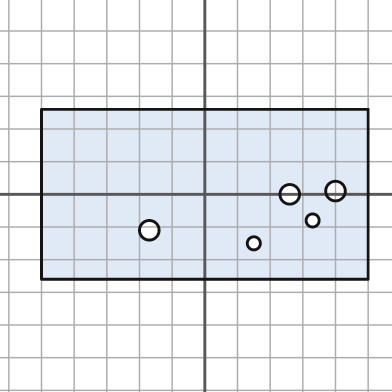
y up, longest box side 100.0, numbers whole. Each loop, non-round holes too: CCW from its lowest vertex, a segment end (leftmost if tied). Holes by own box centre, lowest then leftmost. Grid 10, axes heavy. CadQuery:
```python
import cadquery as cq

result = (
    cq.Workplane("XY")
    .moveTo(-50.0, -26.0)
    .lineTo(50.0, -26.0)
    .lineTo(50.0, 26.0)
    .lineTo(-50.0, 26.0)
    .close()
    .moveTo(15.0, -15.0)
    .circle(2.0)
    .moveTo(-17.0, -11.0)
    .circle(3.0)
    .moveTo(33.0, -8.0)
    .circle(2.0)
    .moveTo(26.0, 0.0)
    .circle(3.0)
    .moveTo(40.0, 1.0)
    .circle(3.0)
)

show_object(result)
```